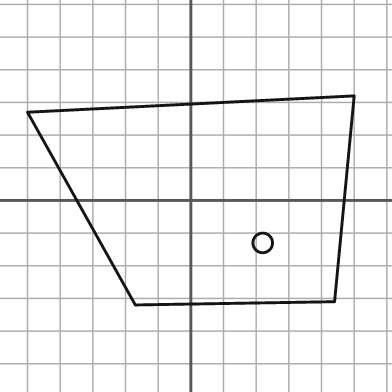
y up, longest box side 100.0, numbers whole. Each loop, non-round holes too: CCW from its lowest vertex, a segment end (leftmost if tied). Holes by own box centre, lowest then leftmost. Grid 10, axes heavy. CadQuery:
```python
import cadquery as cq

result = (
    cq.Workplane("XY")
    .moveTo(-17.0, -32.0)
    .lineTo(44.0, -31.0)
    .lineTo(50.0, 32.0)
    .lineTo(-50.0, 27.0)
    .close()
    .moveTo(22.0, -13.0)
    .circle(3.0)
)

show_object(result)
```